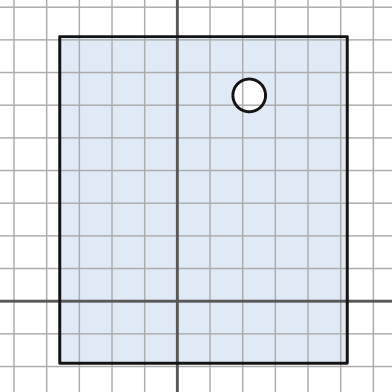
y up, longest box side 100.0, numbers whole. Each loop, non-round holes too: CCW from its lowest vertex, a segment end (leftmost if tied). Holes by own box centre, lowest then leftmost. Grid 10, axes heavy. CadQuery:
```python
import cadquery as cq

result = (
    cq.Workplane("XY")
    .moveTo(-36.0, -19.0)
    .lineTo(52.0, -19.0)
    .lineTo(52.0, 81.0)
    .lineTo(-36.0, 81.0)
    .close()
    .moveTo(22.0, 63.0)
    .circle(5.0)
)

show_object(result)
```